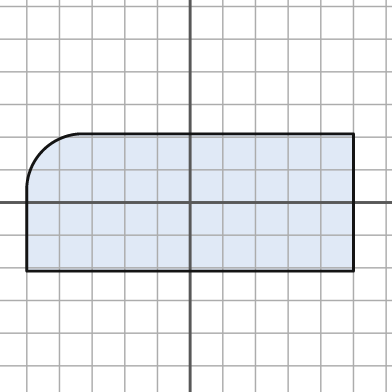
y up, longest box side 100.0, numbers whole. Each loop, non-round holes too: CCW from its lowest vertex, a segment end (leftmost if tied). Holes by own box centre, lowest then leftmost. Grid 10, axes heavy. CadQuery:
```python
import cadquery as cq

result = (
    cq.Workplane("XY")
    .moveTo(-50.0, -21.0)
    .lineTo(50.0, -21.0)
    .lineTo(50.0, 21.0)
    .lineTo(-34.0, 21.0)
    .threePointArc((-45.0, 16.0), (-50.0, 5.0))
    .close()
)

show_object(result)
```